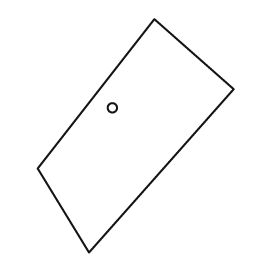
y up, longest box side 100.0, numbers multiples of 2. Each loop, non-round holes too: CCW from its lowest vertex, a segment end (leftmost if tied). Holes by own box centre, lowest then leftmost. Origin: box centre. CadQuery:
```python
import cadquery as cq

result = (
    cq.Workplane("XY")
    .moveTo(-20.0, -50.0)
    .lineTo(42.0, 20.0)
    .lineTo(8.0, 50.0)
    .lineTo(-42.0, -14.0)
    .close()
    .moveTo(-10.0, 12.0)
    .circle(2.0)
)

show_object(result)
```